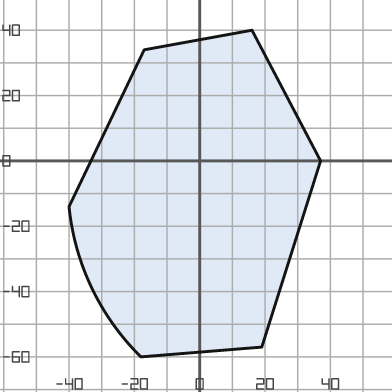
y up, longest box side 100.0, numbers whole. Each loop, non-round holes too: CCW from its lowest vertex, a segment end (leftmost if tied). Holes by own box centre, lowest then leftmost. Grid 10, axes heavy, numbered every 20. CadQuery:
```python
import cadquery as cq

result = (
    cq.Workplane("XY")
    .moveTo(-18.0, -60.0)
    .lineTo(19.0, -57.0)
    .lineTo(37.0, 0.0)
    .lineTo(16.0, 40.0)
    .lineTo(-17.0, 34.0)
    .lineTo(-40.0, -14.0)
    .threePointArc((-33.0, -39.0), (-18.0, -60.0))
    .close()
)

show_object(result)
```